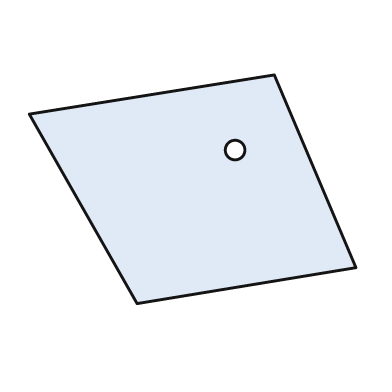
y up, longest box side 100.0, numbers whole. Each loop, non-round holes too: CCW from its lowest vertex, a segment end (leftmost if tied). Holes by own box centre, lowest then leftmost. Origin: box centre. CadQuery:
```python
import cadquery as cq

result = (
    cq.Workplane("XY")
    .moveTo(-17.0, -35.0)
    .lineTo(50.0, -24.0)
    .lineTo(25.0, 35.0)
    .lineTo(-50.0, 23.0)
    .close()
    .moveTo(13.0, 12.0)
    .circle(3.0)
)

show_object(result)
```